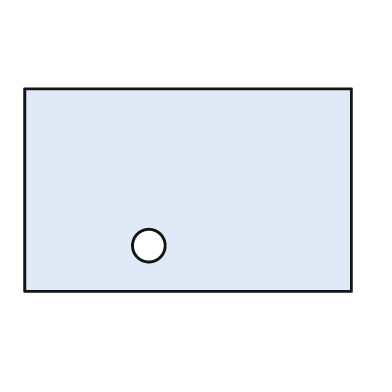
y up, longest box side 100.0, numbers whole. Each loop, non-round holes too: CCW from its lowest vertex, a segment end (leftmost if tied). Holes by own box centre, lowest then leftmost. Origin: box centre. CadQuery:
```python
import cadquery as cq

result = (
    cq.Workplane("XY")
    .moveTo(-50.0, -31.0)
    .lineTo(50.0, -31.0)
    .lineTo(50.0, 31.0)
    .lineTo(-50.0, 31.0)
    .close()
    .moveTo(-12.0, -17.0)
    .circle(5.0)
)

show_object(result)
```